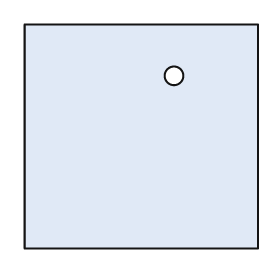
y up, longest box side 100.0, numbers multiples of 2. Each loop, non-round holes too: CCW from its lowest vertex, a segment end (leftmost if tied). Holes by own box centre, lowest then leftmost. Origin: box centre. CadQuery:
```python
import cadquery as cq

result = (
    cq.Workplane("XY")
    .moveTo(-50.0, -48.0)
    .lineTo(50.0, -48.0)
    .lineTo(50.0, 48.0)
    .lineTo(-50.0, 48.0)
    .close()
    .moveTo(14.0, 26.0)
    .circle(4.0)
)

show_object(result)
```